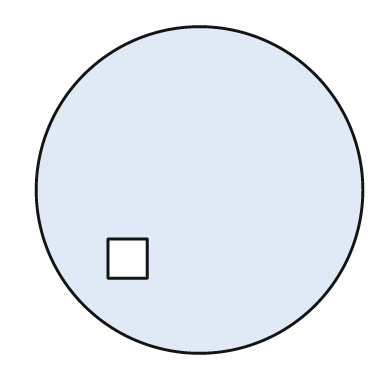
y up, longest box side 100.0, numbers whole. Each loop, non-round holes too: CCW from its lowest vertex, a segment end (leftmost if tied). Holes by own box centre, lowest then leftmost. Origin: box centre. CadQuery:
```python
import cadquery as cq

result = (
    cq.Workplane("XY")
    .moveTo(0.0, 0.0)
    .circle(50.0)
    .moveTo(-28.0, -27.0)
    .lineTo(-16.0, -27.0)
    .lineTo(-16.0, -15.0)
    .lineTo(-28.0, -15.0)
    .close()
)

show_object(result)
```